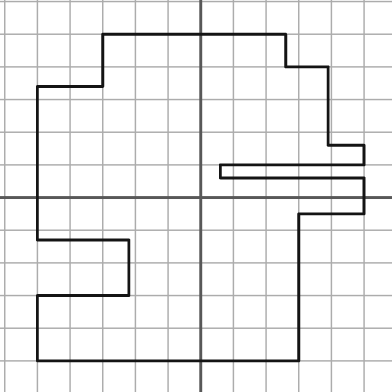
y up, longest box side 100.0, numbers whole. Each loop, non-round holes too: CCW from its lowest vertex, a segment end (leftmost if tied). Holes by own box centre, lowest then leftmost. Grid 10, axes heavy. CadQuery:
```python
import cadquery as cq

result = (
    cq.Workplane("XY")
    .moveTo(-50.0, -50.0)
    .lineTo(30.0, -50.0)
    .lineTo(30.0, -5.0)
    .lineTo(50.0, -5.0)
    .lineTo(50.0, 6.0)
    .lineTo(6.0, 6.0)
    .lineTo(6.0, 10.0)
    .lineTo(50.0, 10.0)
    .lineTo(50.0, 16.0)
    .lineTo(39.0, 16.0)
    .lineTo(39.0, 40.0)
    .lineTo(26.0, 40.0)
    .lineTo(26.0, 50.0)
    .lineTo(-30.0, 50.0)
    .lineTo(-30.0, 34.0)
    .lineTo(-50.0, 34.0)
    .lineTo(-50.0, -13.0)
    .lineTo(-22.0, -13.0)
    .lineTo(-22.0, -30.0)
    .lineTo(-50.0, -30.0)
    .close()
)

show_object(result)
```